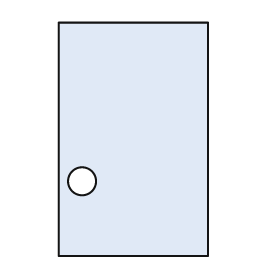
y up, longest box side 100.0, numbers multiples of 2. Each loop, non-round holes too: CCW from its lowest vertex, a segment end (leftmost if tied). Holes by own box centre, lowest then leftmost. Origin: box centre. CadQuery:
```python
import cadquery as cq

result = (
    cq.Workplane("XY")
    .moveTo(-32.0, -50.0)
    .lineTo(32.0, -50.0)
    .lineTo(32.0, 50.0)
    .lineTo(-32.0, 50.0)
    .close()
    .moveTo(-22.0, -18.0)
    .circle(6.0)
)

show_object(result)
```